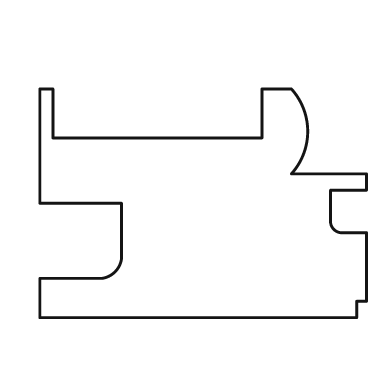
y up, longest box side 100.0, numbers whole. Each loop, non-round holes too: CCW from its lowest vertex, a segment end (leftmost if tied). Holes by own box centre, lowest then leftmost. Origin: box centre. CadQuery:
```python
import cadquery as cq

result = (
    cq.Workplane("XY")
    .moveTo(-50.0, -35.0)
    .lineTo(47.0, -35.0)
    .lineTo(47.0, -30.0)
    .lineTo(50.0, -30.0)
    .lineTo(50.0, -9.0)
    .lineTo(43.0, -9.0)
    .threePointArc((40.0, -8.0), (39.0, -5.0))
    .lineTo(39.0, 4.0)
    .lineTo(50.0, 4.0)
    .lineTo(50.0, 9.0)
    .lineTo(27.0, 9.0)
    .threePointArc((32.0, 22.0), (27.0, 35.0))
    .lineTo(18.0, 35.0)
    .lineTo(18.0, 20.0)
    .lineTo(-46.0, 20.0)
    .lineTo(-46.0, 35.0)
    .lineTo(-50.0, 35.0)
    .lineTo(-50.0, 0.0)
    .lineTo(-25.0, 0.0)
    .lineTo(-25.0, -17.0)
    .threePointArc((-27.0, -21.0), (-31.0, -23.0))
    .lineTo(-50.0, -23.0)
    .close()
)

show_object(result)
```